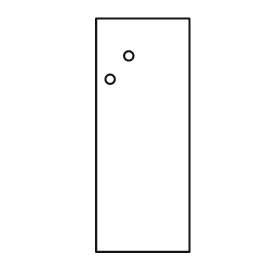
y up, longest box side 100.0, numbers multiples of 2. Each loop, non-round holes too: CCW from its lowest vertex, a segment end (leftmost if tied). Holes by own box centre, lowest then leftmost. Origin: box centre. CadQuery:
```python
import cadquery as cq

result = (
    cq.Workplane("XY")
    .moveTo(-20.0, -50.0)
    .lineTo(20.0, -50.0)
    .lineTo(20.0, 50.0)
    .lineTo(-20.0, 50.0)
    .close()
    .moveTo(-14.0, 24.0)
    .circle(2.0)
    .moveTo(-6.0, 34.0)
    .circle(2.0)
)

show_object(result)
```